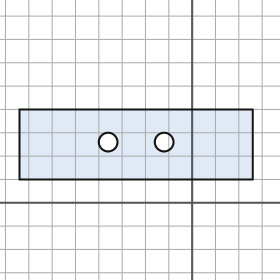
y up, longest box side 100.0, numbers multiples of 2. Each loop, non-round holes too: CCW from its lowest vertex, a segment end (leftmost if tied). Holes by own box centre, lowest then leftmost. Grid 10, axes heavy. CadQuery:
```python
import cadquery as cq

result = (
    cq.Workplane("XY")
    .moveTo(-74.0, 10.0)
    .lineTo(26.0, 10.0)
    .lineTo(26.0, 40.0)
    .lineTo(-74.0, 40.0)
    .close()
    .moveTo(-36.0, 26.0)
    .circle(4.0)
    .moveTo(-12.0, 26.0)
    .circle(4.0)
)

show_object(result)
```